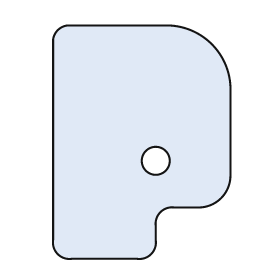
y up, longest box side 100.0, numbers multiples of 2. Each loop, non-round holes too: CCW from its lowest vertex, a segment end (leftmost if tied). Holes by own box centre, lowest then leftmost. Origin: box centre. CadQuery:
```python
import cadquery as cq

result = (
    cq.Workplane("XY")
    .moveTo(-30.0, -50.0)
    .lineTo(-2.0, -50.0)
    .threePointArc((4.0, -48.0), (6.0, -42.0))
    .lineTo(6.0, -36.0)
    .threePointArc((8.0, -30.0), (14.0, -28.0))
    .lineTo(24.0, -28.0)
    .threePointArc((34.0, -24.0), (38.0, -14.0))
    .lineTo(38.0, 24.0)
    .threePointArc((30.0, 42.0), (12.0, 50.0))
    .lineTo(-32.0, 50.0)
    .threePointArc((-36.0, 48.0), (-38.0, 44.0))
    .lineTo(-38.0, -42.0)
    .threePointArc((-36.0, -48.0), (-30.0, -50.0))
    .close()
    .moveTo(6.0, -8.0)
    .circle(6.0)
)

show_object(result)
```